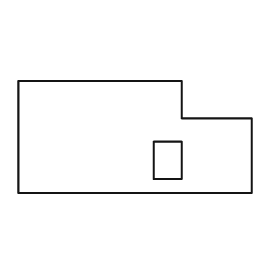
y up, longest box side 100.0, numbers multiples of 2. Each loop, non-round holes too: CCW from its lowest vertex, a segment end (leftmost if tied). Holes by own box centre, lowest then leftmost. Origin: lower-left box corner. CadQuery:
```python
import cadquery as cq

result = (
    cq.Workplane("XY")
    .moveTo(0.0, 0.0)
    .lineTo(100.0, 0.0)
    .lineTo(100.0, 32.0)
    .lineTo(70.0, 32.0)
    .lineTo(70.0, 48.0)
    .lineTo(0.0, 48.0)
    .close()
    .moveTo(58.0, 6.0)
    .lineTo(70.0, 6.0)
    .lineTo(70.0, 22.0)
    .lineTo(58.0, 22.0)
    .close()
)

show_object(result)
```